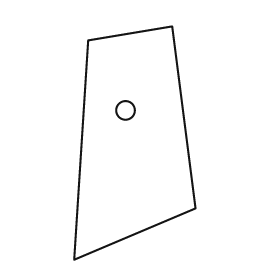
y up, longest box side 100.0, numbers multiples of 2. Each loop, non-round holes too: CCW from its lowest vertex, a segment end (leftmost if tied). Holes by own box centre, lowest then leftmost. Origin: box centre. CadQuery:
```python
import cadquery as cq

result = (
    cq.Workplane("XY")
    .moveTo(-26.0, -50.0)
    .lineTo(26.0, -28.0)
    .lineTo(16.0, 50.0)
    .lineTo(-20.0, 44.0)
    .close()
    .moveTo(-4.0, 14.0)
    .circle(4.0)
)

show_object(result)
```